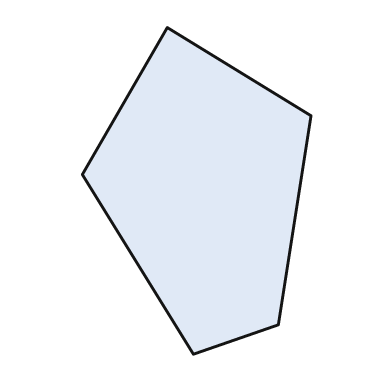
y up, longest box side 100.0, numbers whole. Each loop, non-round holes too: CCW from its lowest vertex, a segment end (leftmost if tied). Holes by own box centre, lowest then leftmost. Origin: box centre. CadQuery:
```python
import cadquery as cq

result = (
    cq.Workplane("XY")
    .moveTo(-1.0, -50.0)
    .lineTo(25.0, -41.0)
    .lineTo(35.0, 23.0)
    .lineTo(-9.0, 50.0)
    .lineTo(-35.0, 5.0)
    .close()
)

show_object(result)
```